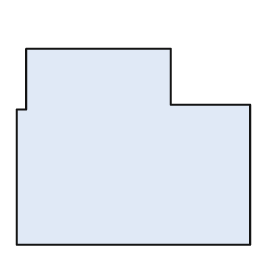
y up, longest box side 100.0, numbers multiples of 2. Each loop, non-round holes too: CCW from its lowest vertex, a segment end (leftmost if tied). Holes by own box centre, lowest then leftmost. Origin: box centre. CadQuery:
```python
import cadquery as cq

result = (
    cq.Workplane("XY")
    .moveTo(-50.0, -42.0)
    .lineTo(50.0, -42.0)
    .lineTo(50.0, 18.0)
    .lineTo(16.0, 18.0)
    .lineTo(16.0, 42.0)
    .lineTo(-46.0, 42.0)
    .lineTo(-46.0, 16.0)
    .lineTo(-50.0, 16.0)
    .close()
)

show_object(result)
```